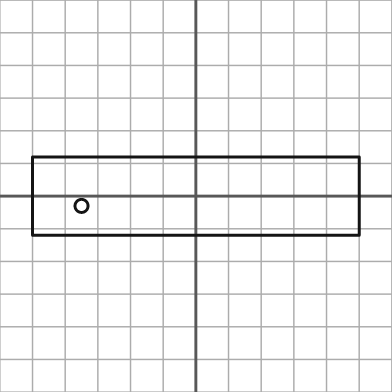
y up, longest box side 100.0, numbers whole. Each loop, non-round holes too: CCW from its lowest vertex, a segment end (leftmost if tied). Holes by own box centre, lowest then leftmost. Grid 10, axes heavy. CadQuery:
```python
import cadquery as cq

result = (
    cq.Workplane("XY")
    .moveTo(-50.0, -12.0)
    .lineTo(50.0, -12.0)
    .lineTo(50.0, 12.0)
    .lineTo(-50.0, 12.0)
    .close()
    .moveTo(-35.0, -3.0)
    .circle(2.0)
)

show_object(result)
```